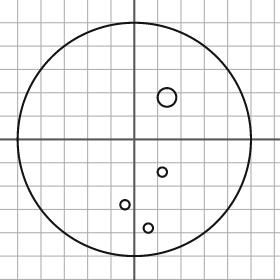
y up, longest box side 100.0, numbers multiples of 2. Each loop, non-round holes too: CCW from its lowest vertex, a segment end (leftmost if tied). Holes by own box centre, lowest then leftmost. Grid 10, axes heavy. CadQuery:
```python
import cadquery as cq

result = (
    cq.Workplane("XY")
    .moveTo(0.0, 0.0)
    .circle(50.0)
    .moveTo(6.0, -38.0)
    .circle(2.0)
    .moveTo(-4.0, -28.0)
    .circle(2.0)
    .moveTo(12.0, -14.0)
    .circle(2.0)
    .moveTo(14.0, 18.0)
    .circle(4.0)
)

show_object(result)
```